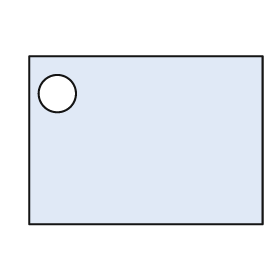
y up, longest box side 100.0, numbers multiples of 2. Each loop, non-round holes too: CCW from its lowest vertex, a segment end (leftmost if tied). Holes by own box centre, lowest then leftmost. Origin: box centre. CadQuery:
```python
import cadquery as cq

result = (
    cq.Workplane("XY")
    .moveTo(-50.0, -36.0)
    .lineTo(50.0, -36.0)
    .lineTo(50.0, 36.0)
    .lineTo(-50.0, 36.0)
    .close()
    .moveTo(-38.0, 20.0)
    .circle(8.0)
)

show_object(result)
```